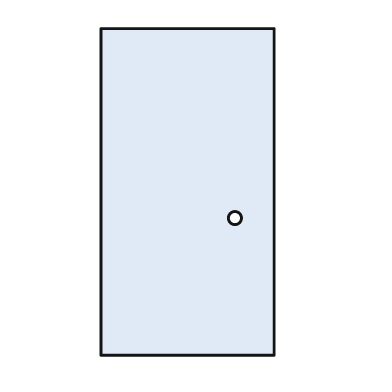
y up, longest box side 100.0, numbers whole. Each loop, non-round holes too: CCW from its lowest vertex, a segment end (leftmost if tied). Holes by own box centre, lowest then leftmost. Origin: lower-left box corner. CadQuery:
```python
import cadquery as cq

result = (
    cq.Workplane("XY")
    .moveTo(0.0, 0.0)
    .lineTo(53.0, 0.0)
    .lineTo(53.0, 100.0)
    .lineTo(0.0, 100.0)
    .close()
    .moveTo(41.0, 42.0)
    .circle(2.0)
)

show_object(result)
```